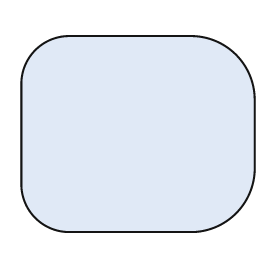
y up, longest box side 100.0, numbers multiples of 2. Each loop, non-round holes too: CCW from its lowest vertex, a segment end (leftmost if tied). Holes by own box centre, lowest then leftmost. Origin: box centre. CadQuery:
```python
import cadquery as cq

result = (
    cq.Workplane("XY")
    .moveTo(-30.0, -42.0)
    .lineTo(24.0, -42.0)
    .threePointArc((42.0, -34.0), (50.0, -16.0))
    .lineTo(50.0, 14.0)
    .threePointArc((42.0, 34.0), (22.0, 42.0))
    .lineTo(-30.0, 42.0)
    .threePointArc((-44.0, 36.0), (-50.0, 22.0))
    .lineTo(-50.0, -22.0)
    .threePointArc((-44.0, -36.0), (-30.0, -42.0))
    .close()
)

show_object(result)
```